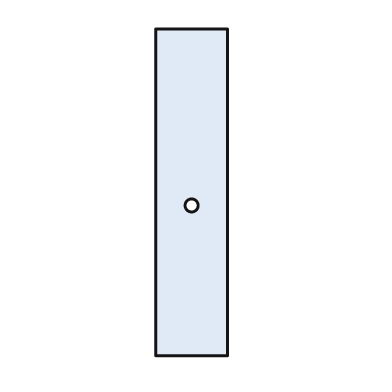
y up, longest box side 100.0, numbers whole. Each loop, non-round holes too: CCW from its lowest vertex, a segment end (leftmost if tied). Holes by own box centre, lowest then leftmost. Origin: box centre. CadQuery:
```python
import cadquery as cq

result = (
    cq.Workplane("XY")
    .moveTo(-11.0, -50.0)
    .lineTo(11.0, -50.0)
    .lineTo(11.0, 50.0)
    .lineTo(-11.0, 50.0)
    .close()
    .moveTo(0.0, -4.0)
    .circle(2.0)
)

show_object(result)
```